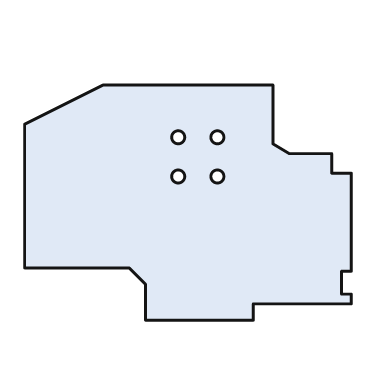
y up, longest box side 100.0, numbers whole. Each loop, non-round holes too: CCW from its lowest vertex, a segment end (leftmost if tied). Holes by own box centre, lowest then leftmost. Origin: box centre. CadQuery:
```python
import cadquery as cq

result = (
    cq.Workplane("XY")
    .moveTo(-13.0, -36.0)
    .lineTo(20.0, -36.0)
    .lineTo(20.0, -31.0)
    .lineTo(50.0, -31.0)
    .lineTo(50.0, -28.0)
    .lineTo(47.0, -28.0)
    .lineTo(47.0, -21.0)
    .lineTo(50.0, -21.0)
    .lineTo(50.0, 9.0)
    .lineTo(44.0, 9.0)
    .lineTo(44.0, 15.0)
    .lineTo(31.0, 15.0)
    .lineTo(26.0, 18.0)
    .lineTo(26.0, 36.0)
    .lineTo(-26.0, 36.0)
    .lineTo(-50.0, 24.0)
    .lineTo(-50.0, -20.0)
    .lineTo(-18.0, -20.0)
    .lineTo(-13.0, -25.0)
    .close()
    .moveTo(-3.0, 8.0)
    .circle(2.0)
    .moveTo(9.0, 8.0)
    .circle(2.0)
    .moveTo(-3.0, 20.0)
    .circle(2.0)
    .moveTo(9.0, 20.0)
    .circle(2.0)
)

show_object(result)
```